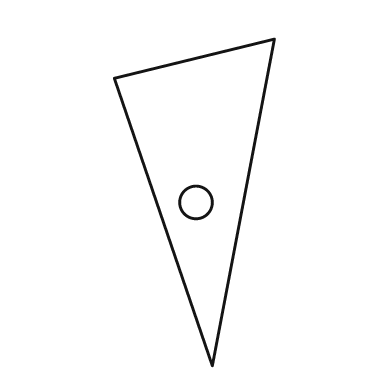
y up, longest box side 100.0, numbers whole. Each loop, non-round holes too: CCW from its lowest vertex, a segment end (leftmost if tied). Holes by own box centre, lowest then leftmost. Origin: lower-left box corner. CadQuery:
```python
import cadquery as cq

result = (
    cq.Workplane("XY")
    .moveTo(30.0, 0.0)
    .lineTo(49.0, 100.0)
    .lineTo(0.0, 88.0)
    .close()
    .moveTo(25.0, 50.0)
    .circle(5.0)
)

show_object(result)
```